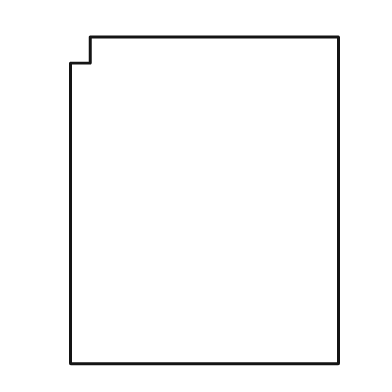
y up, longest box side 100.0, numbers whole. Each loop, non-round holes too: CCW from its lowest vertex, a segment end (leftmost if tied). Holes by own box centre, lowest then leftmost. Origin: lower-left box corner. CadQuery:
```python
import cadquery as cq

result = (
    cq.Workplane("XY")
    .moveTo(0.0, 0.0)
    .lineTo(82.0, 0.0)
    .lineTo(82.0, 100.0)
    .lineTo(6.0, 100.0)
    .lineTo(6.0, 92.0)
    .lineTo(0.0, 92.0)
    .close()
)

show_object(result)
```